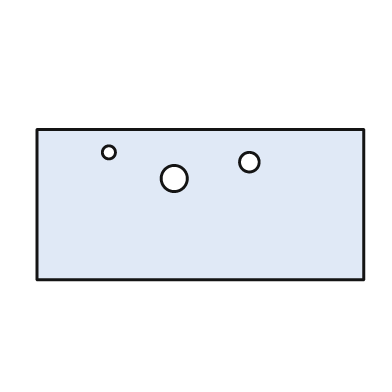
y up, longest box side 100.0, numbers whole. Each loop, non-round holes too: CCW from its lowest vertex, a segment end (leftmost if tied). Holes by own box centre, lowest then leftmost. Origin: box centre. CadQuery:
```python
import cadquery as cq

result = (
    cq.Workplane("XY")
    .moveTo(-50.0, -23.0)
    .lineTo(50.0, -23.0)
    .lineTo(50.0, 23.0)
    .lineTo(-50.0, 23.0)
    .close()
    .moveTo(-8.0, 8.0)
    .circle(4.0)
    .moveTo(15.0, 13.0)
    .circle(3.0)
    .moveTo(-28.0, 16.0)
    .circle(2.0)
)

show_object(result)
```